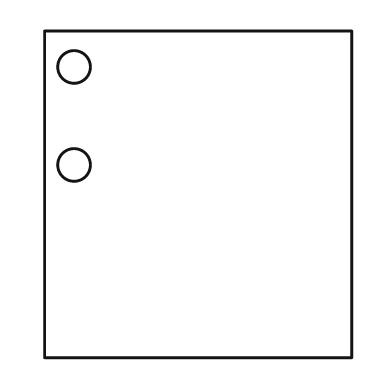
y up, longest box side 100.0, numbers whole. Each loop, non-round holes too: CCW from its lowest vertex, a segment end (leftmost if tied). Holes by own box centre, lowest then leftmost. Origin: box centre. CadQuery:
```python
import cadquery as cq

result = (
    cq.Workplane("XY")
    .moveTo(-47.0, -50.0)
    .lineTo(47.0, -50.0)
    .lineTo(47.0, 50.0)
    .lineTo(-47.0, 50.0)
    .close()
    .moveTo(-38.0, 9.0)
    .circle(5.0)
    .moveTo(-38.0, 39.0)
    .circle(5.0)
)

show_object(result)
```